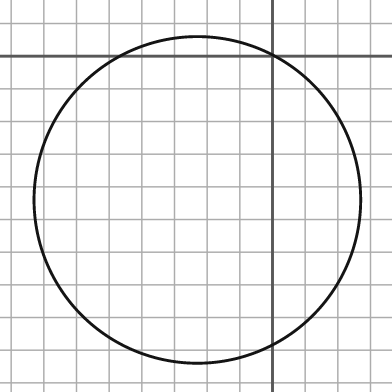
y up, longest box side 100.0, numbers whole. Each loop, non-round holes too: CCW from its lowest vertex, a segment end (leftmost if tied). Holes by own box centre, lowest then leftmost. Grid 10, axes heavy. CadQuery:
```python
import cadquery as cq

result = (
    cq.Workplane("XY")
    .moveTo(-23.0, -44.0)
    .circle(50.0)
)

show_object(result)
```